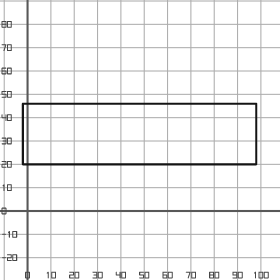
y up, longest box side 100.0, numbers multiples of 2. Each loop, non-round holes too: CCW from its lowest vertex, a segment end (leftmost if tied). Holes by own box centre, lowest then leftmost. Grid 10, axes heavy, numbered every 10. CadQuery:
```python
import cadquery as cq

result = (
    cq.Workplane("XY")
    .moveTo(-2.0, 20.0)
    .lineTo(98.0, 20.0)
    .lineTo(98.0, 46.0)
    .lineTo(-2.0, 46.0)
    .close()
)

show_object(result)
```